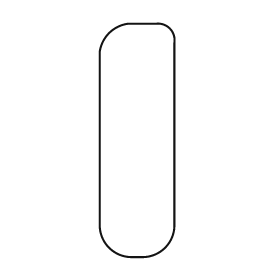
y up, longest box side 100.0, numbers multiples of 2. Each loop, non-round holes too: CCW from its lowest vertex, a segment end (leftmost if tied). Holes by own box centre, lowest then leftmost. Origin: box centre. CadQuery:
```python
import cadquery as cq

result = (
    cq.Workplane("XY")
    .moveTo(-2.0, -50.0)
    .lineTo(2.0, -50.0)
    .threePointArc((12.0, -46.0), (16.0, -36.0))
    .lineTo(16.0, 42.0)
    .threePointArc((14.0, 48.0), (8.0, 50.0))
    .lineTo(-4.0, 50.0)
    .threePointArc((-12.0, 46.0), (-16.0, 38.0))
    .lineTo(-16.0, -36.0)
    .threePointArc((-12.0, -46.0), (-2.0, -50.0))
    .close()
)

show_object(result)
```